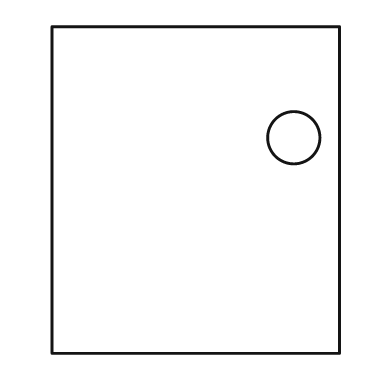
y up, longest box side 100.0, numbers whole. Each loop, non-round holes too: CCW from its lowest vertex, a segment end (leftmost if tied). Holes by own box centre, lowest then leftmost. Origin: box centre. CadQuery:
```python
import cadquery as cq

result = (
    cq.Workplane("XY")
    .moveTo(-44.0, -50.0)
    .lineTo(44.0, -50.0)
    .lineTo(44.0, 50.0)
    .lineTo(-44.0, 50.0)
    .close()
    .moveTo(30.0, 16.0)
    .circle(8.0)
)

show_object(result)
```